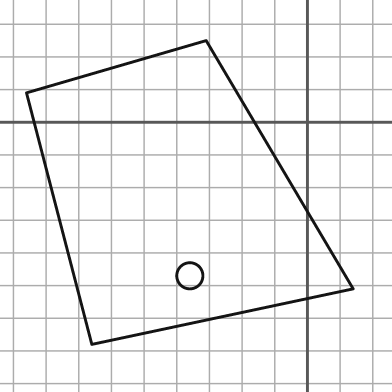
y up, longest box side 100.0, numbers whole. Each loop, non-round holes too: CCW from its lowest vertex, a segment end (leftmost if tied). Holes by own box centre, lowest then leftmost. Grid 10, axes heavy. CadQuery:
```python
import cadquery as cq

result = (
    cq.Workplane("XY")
    .moveTo(-66.0, -68.0)
    .lineTo(14.0, -51.0)
    .lineTo(-31.0, 25.0)
    .lineTo(-86.0, 9.0)
    .close()
    .moveTo(-36.0, -47.0)
    .circle(4.0)
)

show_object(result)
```